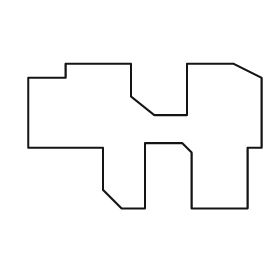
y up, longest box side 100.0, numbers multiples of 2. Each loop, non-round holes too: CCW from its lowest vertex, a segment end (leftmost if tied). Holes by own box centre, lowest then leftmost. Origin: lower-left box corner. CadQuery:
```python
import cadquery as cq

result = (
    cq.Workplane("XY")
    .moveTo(40.0, 0.0)
    .lineTo(50.0, 0.0)
    .lineTo(50.0, 28.0)
    .lineTo(66.0, 28.0)
    .lineTo(70.0, 24.0)
    .lineTo(70.0, 0.0)
    .lineTo(94.0, 0.0)
    .lineTo(94.0, 26.0)
    .lineTo(100.0, 26.0)
    .lineTo(100.0, 56.0)
    .lineTo(88.0, 62.0)
    .lineTo(68.0, 62.0)
    .lineTo(68.0, 40.0)
    .lineTo(54.0, 40.0)
    .lineTo(44.0, 48.0)
    .lineTo(44.0, 62.0)
    .lineTo(16.0, 62.0)
    .lineTo(16.0, 56.0)
    .lineTo(0.0, 56.0)
    .lineTo(0.0, 26.0)
    .lineTo(32.0, 26.0)
    .lineTo(32.0, 8.0)
    .close()
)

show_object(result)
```